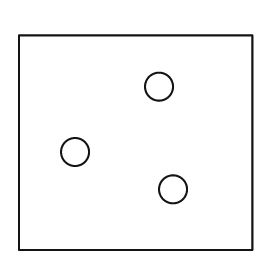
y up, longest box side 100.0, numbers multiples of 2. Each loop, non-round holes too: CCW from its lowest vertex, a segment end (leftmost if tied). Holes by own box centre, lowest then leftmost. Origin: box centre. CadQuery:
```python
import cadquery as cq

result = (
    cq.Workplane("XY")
    .moveTo(-50.0, -46.0)
    .lineTo(50.0, -46.0)
    .lineTo(50.0, 46.0)
    .lineTo(-50.0, 46.0)
    .close()
    .moveTo(16.0, -20.0)
    .circle(6.0)
    .moveTo(-26.0, -4.0)
    .circle(6.0)
    .moveTo(10.0, 24.0)
    .circle(6.0)
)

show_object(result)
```